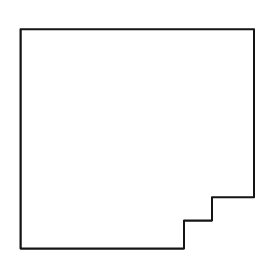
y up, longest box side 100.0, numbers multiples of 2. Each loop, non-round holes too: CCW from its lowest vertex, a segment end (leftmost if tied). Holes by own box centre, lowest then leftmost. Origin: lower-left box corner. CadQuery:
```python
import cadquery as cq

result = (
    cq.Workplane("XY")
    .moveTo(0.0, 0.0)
    .lineTo(70.0, 0.0)
    .lineTo(70.0, 12.0)
    .lineTo(82.0, 12.0)
    .lineTo(82.0, 22.0)
    .lineTo(100.0, 22.0)
    .lineTo(100.0, 94.0)
    .lineTo(0.0, 94.0)
    .close()
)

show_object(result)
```